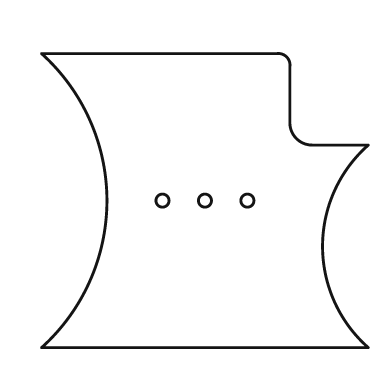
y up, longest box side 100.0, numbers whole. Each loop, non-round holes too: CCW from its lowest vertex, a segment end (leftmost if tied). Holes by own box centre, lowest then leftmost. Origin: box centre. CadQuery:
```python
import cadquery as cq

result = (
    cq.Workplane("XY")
    .moveTo(-50.0, -45.0)
    .lineTo(50.0, -45.0)
    .threePointArc((36.0, -14.0), (50.0, 17.0))
    .lineTo(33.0, 17.0)
    .threePointArc((28.0, 19.0), (26.0, 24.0))
    .lineTo(26.0, 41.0)
    .threePointArc((25.0, 44.0), (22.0, 45.0))
    .lineTo(-50.0, 45.0)
    .threePointArc((-30.0, 0.0), (-50.0, -45.0))
    .close()
    .moveTo(-13.0, 0.0)
    .circle(2.0)
    .moveTo(0.0, 0.0)
    .circle(2.0)
    .moveTo(13.0, 0.0)
    .circle(2.0)
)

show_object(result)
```